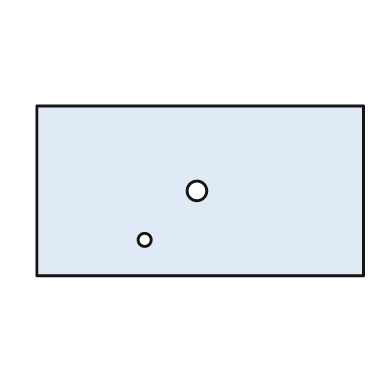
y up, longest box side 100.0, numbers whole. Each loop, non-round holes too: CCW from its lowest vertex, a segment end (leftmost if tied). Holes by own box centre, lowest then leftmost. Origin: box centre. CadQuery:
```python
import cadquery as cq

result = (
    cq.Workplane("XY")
    .moveTo(-50.0, -26.0)
    .lineTo(50.0, -26.0)
    .lineTo(50.0, 26.0)
    .lineTo(-50.0, 26.0)
    .close()
    .moveTo(-17.0, -15.0)
    .circle(2.0)
    .moveTo(-1.0, 0.0)
    .circle(3.0)
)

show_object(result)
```